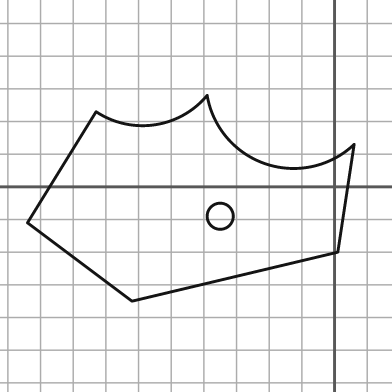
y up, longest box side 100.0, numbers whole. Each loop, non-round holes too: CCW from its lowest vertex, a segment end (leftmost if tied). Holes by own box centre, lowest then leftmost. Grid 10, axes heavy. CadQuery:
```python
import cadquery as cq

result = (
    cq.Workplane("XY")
    .moveTo(-62.0, -35.0)
    .lineTo(1.0, -20.0)
    .lineTo(6.0, 13.0)
    .threePointArc((-21.0, 7.0), (-39.0, 28.0))
    .threePointArc((-55.0, 19.0), (-73.0, 23.0))
    .lineTo(-94.0, -11.0)
    .close()
    .moveTo(-35.0, -9.0)
    .circle(4.0)
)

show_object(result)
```